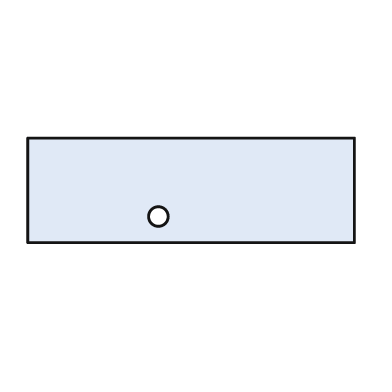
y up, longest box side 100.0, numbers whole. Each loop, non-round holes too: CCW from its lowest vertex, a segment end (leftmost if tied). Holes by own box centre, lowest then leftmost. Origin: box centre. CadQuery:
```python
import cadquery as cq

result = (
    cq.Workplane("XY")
    .moveTo(-50.0, -16.0)
    .lineTo(50.0, -16.0)
    .lineTo(50.0, 16.0)
    .lineTo(-50.0, 16.0)
    .close()
    .moveTo(-10.0, -8.0)
    .circle(3.0)
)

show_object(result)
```